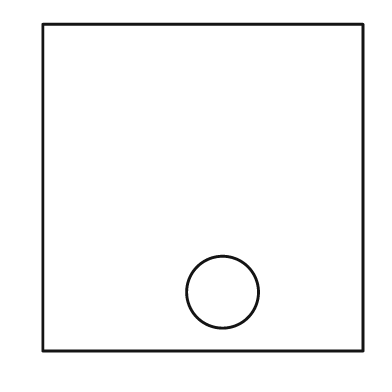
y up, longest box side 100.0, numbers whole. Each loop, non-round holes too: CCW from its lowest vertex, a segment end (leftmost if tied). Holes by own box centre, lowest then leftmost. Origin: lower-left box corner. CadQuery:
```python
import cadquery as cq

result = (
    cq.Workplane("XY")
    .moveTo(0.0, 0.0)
    .lineTo(98.0, 0.0)
    .lineTo(98.0, 100.0)
    .lineTo(0.0, 100.0)
    .close()
    .moveTo(55.0, 18.0)
    .circle(11.0)
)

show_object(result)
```